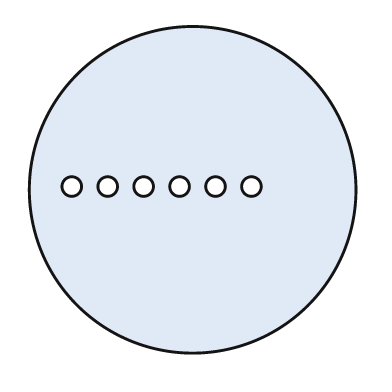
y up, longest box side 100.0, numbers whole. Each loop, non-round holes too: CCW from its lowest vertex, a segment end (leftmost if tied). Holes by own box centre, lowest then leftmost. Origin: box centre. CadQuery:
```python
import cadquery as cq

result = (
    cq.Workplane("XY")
    .moveTo(0.0, 0.0)
    .circle(50.0)
    .moveTo(-37.0, 1.0)
    .circle(3.0)
    .moveTo(-26.0, 1.0)
    .circle(3.0)
    .moveTo(-15.0, 1.0)
    .circle(3.0)
    .moveTo(-4.0, 1.0)
    .circle(3.0)
    .moveTo(7.0, 1.0)
    .circle(3.0)
    .moveTo(18.0, 1.0)
    .circle(3.0)
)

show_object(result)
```